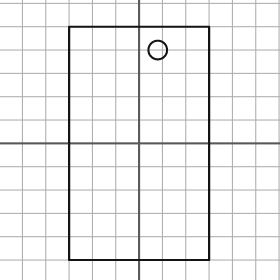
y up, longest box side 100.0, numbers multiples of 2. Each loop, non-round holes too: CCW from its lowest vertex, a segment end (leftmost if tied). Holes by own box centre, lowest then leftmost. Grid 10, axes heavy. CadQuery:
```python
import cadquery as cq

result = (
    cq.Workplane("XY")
    .moveTo(-30.0, -50.0)
    .lineTo(30.0, -50.0)
    .lineTo(30.0, 50.0)
    .lineTo(-30.0, 50.0)
    .close()
    .moveTo(8.0, 40.0)
    .circle(4.0)
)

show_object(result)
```